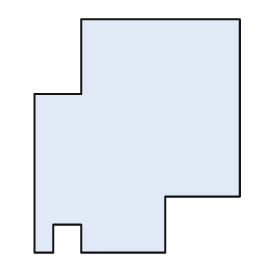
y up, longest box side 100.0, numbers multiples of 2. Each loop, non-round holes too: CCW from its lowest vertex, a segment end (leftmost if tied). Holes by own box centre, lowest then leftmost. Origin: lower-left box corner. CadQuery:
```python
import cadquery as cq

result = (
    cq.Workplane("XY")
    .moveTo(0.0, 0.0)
    .lineTo(8.0, 0.0)
    .lineTo(8.0, 12.0)
    .lineTo(20.0, 12.0)
    .lineTo(20.0, 0.0)
    .lineTo(56.0, 0.0)
    .lineTo(56.0, 24.0)
    .lineTo(88.0, 24.0)
    .lineTo(88.0, 100.0)
    .lineTo(20.0, 100.0)
    .lineTo(20.0, 68.0)
    .lineTo(0.0, 68.0)
    .close()
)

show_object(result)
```